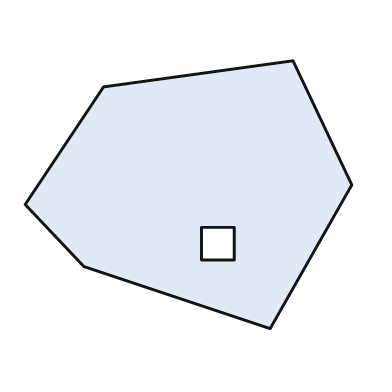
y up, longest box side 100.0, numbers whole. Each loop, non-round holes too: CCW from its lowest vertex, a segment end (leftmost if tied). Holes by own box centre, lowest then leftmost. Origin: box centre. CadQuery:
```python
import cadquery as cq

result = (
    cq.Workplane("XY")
    .moveTo(25.0, -41.0)
    .lineTo(50.0, 3.0)
    .lineTo(32.0, 41.0)
    .lineTo(-26.0, 33.0)
    .lineTo(-50.0, -3.0)
    .lineTo(-32.0, -22.0)
    .close()
    .moveTo(4.0, -20.0)
    .lineTo(14.0, -20.0)
    .lineTo(14.0, -10.0)
    .lineTo(4.0, -10.0)
    .close()
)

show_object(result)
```